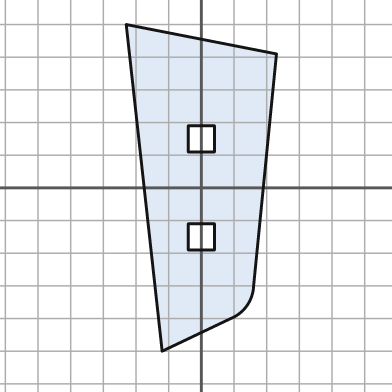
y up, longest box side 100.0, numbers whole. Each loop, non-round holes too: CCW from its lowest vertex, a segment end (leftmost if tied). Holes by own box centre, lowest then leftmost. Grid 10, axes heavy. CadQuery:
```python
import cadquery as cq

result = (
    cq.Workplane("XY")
    .moveTo(-12.0, -50.0)
    .lineTo(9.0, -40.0)
    .threePointArc((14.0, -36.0), (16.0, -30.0))
    .lineTo(23.0, 41.0)
    .lineTo(-23.0, 50.0)
    .close()
    .moveTo(-4.0, -19.0)
    .lineTo(4.0, -19.0)
    .lineTo(4.0, -11.0)
    .lineTo(-4.0, -11.0)
    .close()
    .moveTo(-4.0, 11.0)
    .lineTo(4.0, 11.0)
    .lineTo(4.0, 19.0)
    .lineTo(-4.0, 19.0)
    .close()
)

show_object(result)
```